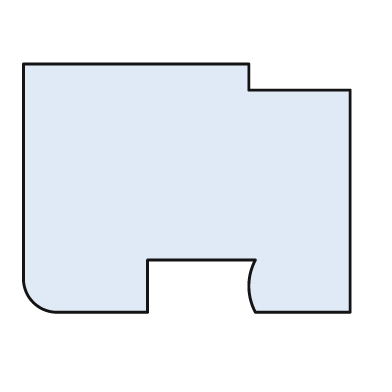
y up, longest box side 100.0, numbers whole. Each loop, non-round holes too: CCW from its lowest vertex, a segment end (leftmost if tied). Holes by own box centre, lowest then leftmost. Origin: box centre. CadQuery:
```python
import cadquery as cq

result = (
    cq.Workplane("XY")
    .moveTo(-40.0, -38.0)
    .lineTo(-12.0, -38.0)
    .lineTo(-12.0, -22.0)
    .lineTo(21.0, -22.0)
    .threePointArc((19.0, -30.0), (21.0, -38.0))
    .lineTo(50.0, -38.0)
    .lineTo(50.0, 30.0)
    .lineTo(19.0, 30.0)
    .lineTo(19.0, 38.0)
    .lineTo(-50.0, 38.0)
    .lineTo(-50.0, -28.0)
    .threePointArc((-47.0, -35.0), (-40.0, -38.0))
    .close()
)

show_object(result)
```